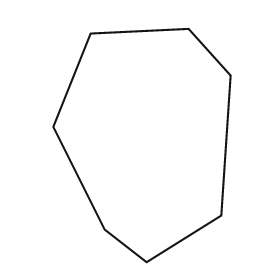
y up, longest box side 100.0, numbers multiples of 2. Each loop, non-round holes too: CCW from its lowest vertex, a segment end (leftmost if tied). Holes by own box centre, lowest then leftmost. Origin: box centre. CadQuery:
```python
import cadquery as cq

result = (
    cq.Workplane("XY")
    .moveTo(2.0, -50.0)
    .lineTo(34.0, -30.0)
    .lineTo(38.0, 30.0)
    .lineTo(20.0, 50.0)
    .lineTo(-22.0, 48.0)
    .lineTo(-38.0, 8.0)
    .lineTo(-16.0, -36.0)
    .close()
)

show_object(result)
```